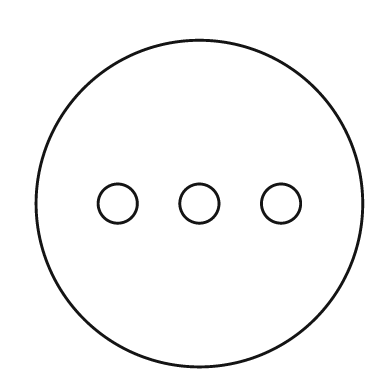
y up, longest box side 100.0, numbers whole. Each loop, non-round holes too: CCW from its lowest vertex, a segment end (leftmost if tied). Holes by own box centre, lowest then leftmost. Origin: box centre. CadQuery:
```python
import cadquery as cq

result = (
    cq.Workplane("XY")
    .moveTo(0.0, 0.0)
    .circle(50.0)
    .moveTo(-25.0, 0.0)
    .circle(6.0)
    .moveTo(0.0, 0.0)
    .circle(6.0)
    .moveTo(25.0, 0.0)
    .circle(6.0)
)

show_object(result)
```